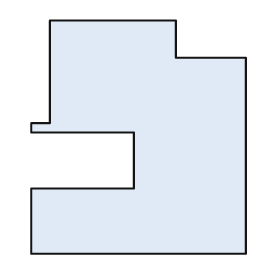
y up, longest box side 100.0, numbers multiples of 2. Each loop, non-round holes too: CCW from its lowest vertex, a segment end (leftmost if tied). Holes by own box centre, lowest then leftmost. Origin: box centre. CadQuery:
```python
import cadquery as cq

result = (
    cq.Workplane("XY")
    .moveTo(-46.0, -50.0)
    .lineTo(46.0, -50.0)
    .lineTo(46.0, 34.0)
    .lineTo(16.0, 34.0)
    .lineTo(16.0, 50.0)
    .lineTo(-38.0, 50.0)
    .lineTo(-38.0, 6.0)
    .lineTo(-46.0, 6.0)
    .lineTo(-46.0, 2.0)
    .lineTo(-2.0, 2.0)
    .lineTo(-2.0, -22.0)
    .lineTo(-46.0, -22.0)
    .close()
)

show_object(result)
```